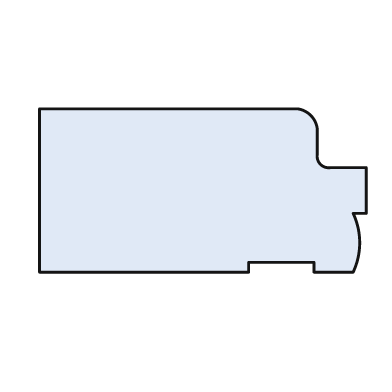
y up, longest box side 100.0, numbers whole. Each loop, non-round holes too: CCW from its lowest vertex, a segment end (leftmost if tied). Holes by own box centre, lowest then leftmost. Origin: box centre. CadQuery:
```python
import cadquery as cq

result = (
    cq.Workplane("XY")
    .moveTo(-50.0, -25.0)
    .lineTo(14.0, -25.0)
    .lineTo(14.0, -22.0)
    .lineTo(34.0, -22.0)
    .lineTo(34.0, -25.0)
    .lineTo(46.0, -25.0)
    .threePointArc((48.0, -16.0), (46.0, -7.0))
    .lineTo(50.0, -7.0)
    .lineTo(50.0, 7.0)
    .lineTo(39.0, 7.0)
    .threePointArc((36.0, 8.0), (35.0, 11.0))
    .lineTo(35.0, 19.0)
    .threePointArc((33.0, 23.0), (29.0, 25.0))
    .lineTo(-50.0, 25.0)
    .close()
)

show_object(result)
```